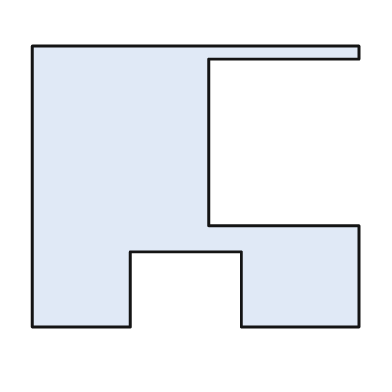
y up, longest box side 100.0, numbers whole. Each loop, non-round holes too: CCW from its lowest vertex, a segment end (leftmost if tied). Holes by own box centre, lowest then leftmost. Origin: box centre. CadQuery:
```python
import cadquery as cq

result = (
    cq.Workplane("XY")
    .moveTo(-50.0, -43.0)
    .lineTo(-20.0, -43.0)
    .lineTo(-20.0, -20.0)
    .lineTo(14.0, -20.0)
    .lineTo(14.0, -43.0)
    .lineTo(50.0, -43.0)
    .lineTo(50.0, -12.0)
    .lineTo(4.0, -12.0)
    .lineTo(4.0, 39.0)
    .lineTo(50.0, 39.0)
    .lineTo(50.0, 43.0)
    .lineTo(-50.0, 43.0)
    .close()
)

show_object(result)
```